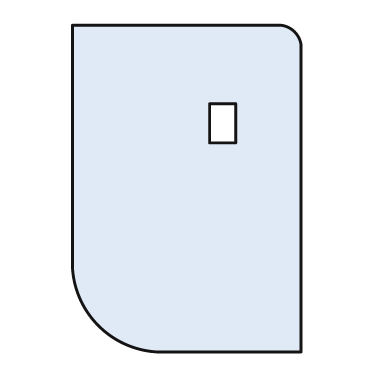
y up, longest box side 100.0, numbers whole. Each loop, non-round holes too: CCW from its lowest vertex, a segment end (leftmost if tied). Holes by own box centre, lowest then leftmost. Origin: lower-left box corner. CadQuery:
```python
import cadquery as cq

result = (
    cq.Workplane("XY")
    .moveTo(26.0, 0.0)
    .lineTo(70.0, 0.0)
    .lineTo(70.0, 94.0)
    .threePointArc((68.0, 98.0), (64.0, 100.0))
    .lineTo(0.0, 100.0)
    .lineTo(0.0, 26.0)
    .threePointArc((8.0, 8.0), (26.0, 0.0))
    .close()
    .moveTo(42.0, 64.0)
    .lineTo(50.0, 64.0)
    .lineTo(50.0, 76.0)
    .lineTo(42.0, 76.0)
    .close()
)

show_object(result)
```